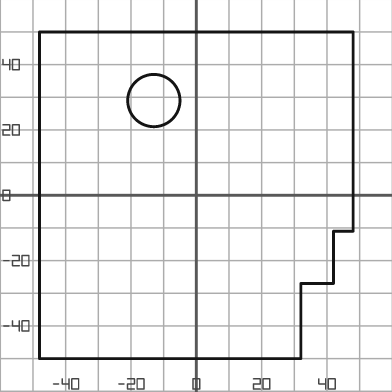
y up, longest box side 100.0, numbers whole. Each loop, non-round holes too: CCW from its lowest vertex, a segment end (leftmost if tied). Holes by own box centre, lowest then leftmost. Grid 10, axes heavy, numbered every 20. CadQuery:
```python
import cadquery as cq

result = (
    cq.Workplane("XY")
    .moveTo(-48.0, -50.0)
    .lineTo(32.0, -50.0)
    .lineTo(32.0, -27.0)
    .lineTo(42.0, -27.0)
    .lineTo(42.0, -11.0)
    .lineTo(48.0, -11.0)
    .lineTo(48.0, 50.0)
    .lineTo(-48.0, 50.0)
    .close()
    .moveTo(-13.0, 29.0)
    .circle(8.0)
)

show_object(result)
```